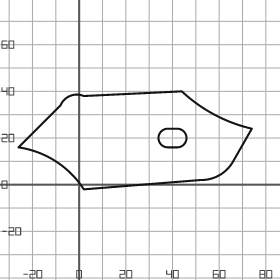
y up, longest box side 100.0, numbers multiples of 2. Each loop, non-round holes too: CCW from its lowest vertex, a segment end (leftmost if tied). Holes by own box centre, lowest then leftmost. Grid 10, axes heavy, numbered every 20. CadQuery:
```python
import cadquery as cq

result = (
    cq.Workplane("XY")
    .moveTo(2.0, -2.0)
    .lineTo(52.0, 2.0)
    .threePointArc((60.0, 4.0), (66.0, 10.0))
    .lineTo(74.0, 24.0)
    .threePointArc((58.0, 30.0), (44.0, 40.0))
    .lineTo(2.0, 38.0)
    .threePointArc((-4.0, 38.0), (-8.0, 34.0))
    .lineTo(-26.0, 16.0)
    .threePointArc((-10.0, 10.0), (2.0, -2.0))
    .close()
    .moveTo(38.0, 16.0)
    .lineTo(42.0, 16.0)
    .threePointArc((46.0, 20.0), (42.0, 24.0))
    .lineTo(38.0, 24.0)
    .threePointArc((34.0, 20.0), (38.0, 16.0))
    .close()
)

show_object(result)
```